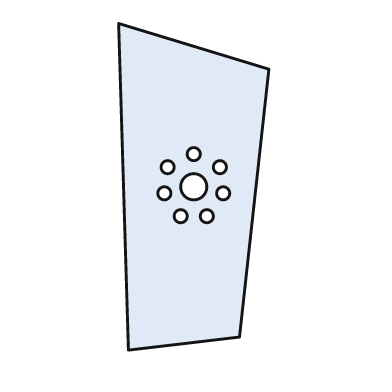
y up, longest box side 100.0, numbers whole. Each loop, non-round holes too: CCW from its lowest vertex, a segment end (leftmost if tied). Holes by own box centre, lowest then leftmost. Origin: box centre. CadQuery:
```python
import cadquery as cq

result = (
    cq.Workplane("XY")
    .moveTo(-20.0, -50.0)
    .lineTo(14.0, -46.0)
    .lineTo(23.0, 36.0)
    .lineTo(-23.0, 50.0)
    .close()
    .moveTo(-4.0, -9.0)
    .circle(2.0)
    .moveTo(4.0, -9.0)
    .circle(2.0)
    .moveTo(-9.0, -2.0)
    .circle(2.0)
    .moveTo(9.0, -2.0)
    .circle(2.0)
    .moveTo(0.0, 0.0)
    .circle(4.0)
    .moveTo(-8.0, 6.0)
    .circle(2.0)
    .moveTo(8.0, 6.0)
    .circle(2.0)
    .moveTo(0.0, 10.0)
    .circle(2.0)
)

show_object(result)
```